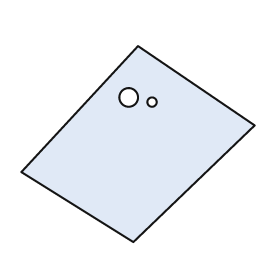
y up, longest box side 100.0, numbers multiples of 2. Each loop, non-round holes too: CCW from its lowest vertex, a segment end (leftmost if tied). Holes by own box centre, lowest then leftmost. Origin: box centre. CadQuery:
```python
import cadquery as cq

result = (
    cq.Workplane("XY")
    .moveTo(-2.0, -42.0)
    .lineTo(50.0, 8.0)
    .lineTo(0.0, 42.0)
    .lineTo(-50.0, -12.0)
    .close()
    .moveTo(6.0, 18.0)
    .circle(2.0)
    .moveTo(-4.0, 20.0)
    .circle(4.0)
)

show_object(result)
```